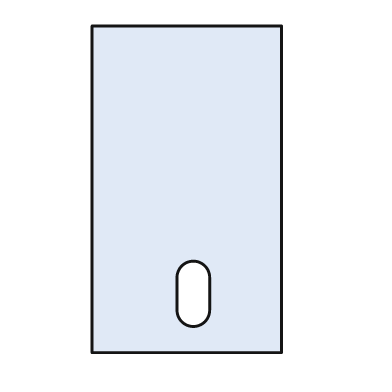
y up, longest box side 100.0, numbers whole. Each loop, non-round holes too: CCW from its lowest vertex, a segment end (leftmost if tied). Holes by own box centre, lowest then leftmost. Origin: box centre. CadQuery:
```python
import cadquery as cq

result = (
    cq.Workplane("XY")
    .moveTo(-29.0, -50.0)
    .lineTo(29.0, -50.0)
    .lineTo(29.0, 50.0)
    .lineTo(-29.0, 50.0)
    .close()
    .moveTo(-3.0, -37.0)
    .threePointArc((2.0, -42.0), (7.0, -37.0))
    .lineTo(7.0, -27.0)
    .threePointArc((2.0, -22.0), (-3.0, -27.0))
    .close()
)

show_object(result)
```